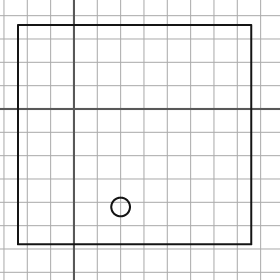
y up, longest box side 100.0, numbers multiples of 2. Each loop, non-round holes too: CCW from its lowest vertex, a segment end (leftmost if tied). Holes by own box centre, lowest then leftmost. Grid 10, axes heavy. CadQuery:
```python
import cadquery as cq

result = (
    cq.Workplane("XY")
    .moveTo(-24.0, -58.0)
    .lineTo(76.0, -58.0)
    .lineTo(76.0, 36.0)
    .lineTo(-24.0, 36.0)
    .close()
    .moveTo(20.0, -42.0)
    .circle(4.0)
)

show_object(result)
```